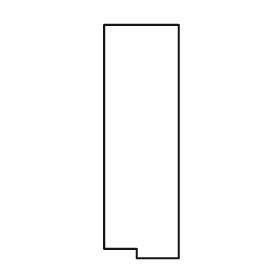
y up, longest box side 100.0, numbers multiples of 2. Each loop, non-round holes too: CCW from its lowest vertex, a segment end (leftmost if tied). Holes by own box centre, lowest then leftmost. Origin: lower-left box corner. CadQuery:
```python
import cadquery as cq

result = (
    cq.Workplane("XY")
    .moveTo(14.0, 0.0)
    .lineTo(32.0, 0.0)
    .lineTo(32.0, 100.0)
    .lineTo(0.0, 100.0)
    .lineTo(0.0, 4.0)
    .lineTo(14.0, 4.0)
    .close()
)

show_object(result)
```